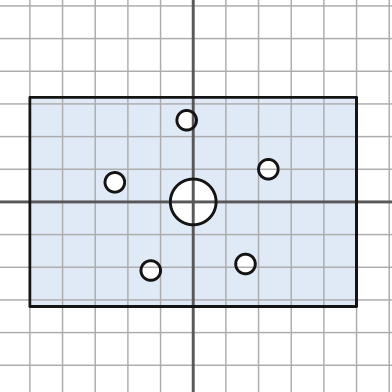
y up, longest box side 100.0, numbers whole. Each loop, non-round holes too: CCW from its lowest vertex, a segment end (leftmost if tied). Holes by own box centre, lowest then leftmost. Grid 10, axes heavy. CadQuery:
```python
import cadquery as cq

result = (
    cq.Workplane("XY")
    .moveTo(-50.0, -32.0)
    .lineTo(50.0, -32.0)
    .lineTo(50.0, 32.0)
    .lineTo(-50.0, 32.0)
    .close()
    .moveTo(-13.0, -21.0)
    .circle(3.0)
    .moveTo(16.0, -19.0)
    .circle(3.0)
    .moveTo(0.0, 0.0)
    .circle(7.0)
    .moveTo(-24.0, 6.0)
    .circle(3.0)
    .moveTo(23.0, 10.0)
    .circle(3.0)
    .moveTo(-2.0, 25.0)
    .circle(3.0)
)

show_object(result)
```